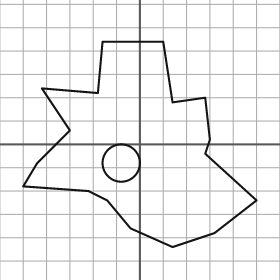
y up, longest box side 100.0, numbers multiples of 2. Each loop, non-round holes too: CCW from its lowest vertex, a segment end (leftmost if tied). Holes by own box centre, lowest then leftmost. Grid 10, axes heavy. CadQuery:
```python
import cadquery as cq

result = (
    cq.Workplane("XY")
    .moveTo(14.0, -44.0)
    .lineTo(32.0, -38.0)
    .lineTo(50.0, -24.0)
    .lineTo(28.0, -4.0)
    .lineTo(30.0, 2.0)
    .lineTo(28.0, 20.0)
    .lineTo(14.0, 18.0)
    .lineTo(10.0, 44.0)
    .lineTo(-16.0, 44.0)
    .lineTo(-18.0, 22.0)
    .lineTo(-42.0, 24.0)
    .lineTo(-30.0, 6.0)
    .lineTo(-44.0, -8.0)
    .lineTo(-50.0, -18.0)
    .lineTo(-22.0, -20.0)
    .lineTo(-14.0, -24.0)
    .lineTo(-4.0, -36.0)
    .close()
    .moveTo(-8.0, -8.0)
    .circle(8.0)
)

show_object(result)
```